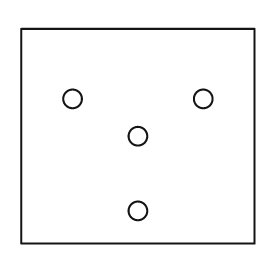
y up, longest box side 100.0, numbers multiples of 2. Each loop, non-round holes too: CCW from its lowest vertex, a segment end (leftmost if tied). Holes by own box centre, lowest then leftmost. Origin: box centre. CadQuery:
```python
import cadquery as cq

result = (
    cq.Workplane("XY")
    .moveTo(-50.0, -46.0)
    .lineTo(50.0, -46.0)
    .lineTo(50.0, 46.0)
    .lineTo(-50.0, 46.0)
    .close()
    .moveTo(0.0, -32.0)
    .circle(4.0)
    .moveTo(0.0, 0.0)
    .circle(4.0)
    .moveTo(-28.0, 16.0)
    .circle(4.0)
    .moveTo(28.0, 16.0)
    .circle(4.0)
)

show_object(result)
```